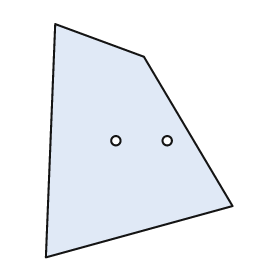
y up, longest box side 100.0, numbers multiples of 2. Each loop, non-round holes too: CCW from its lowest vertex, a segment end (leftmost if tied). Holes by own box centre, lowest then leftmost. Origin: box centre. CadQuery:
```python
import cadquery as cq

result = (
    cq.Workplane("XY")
    .moveTo(-40.0, -50.0)
    .lineTo(40.0, -28.0)
    .lineTo(2.0, 36.0)
    .lineTo(-36.0, 50.0)
    .close()
    .moveTo(-10.0, 0.0)
    .circle(2.0)
    .moveTo(12.0, 0.0)
    .circle(2.0)
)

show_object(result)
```